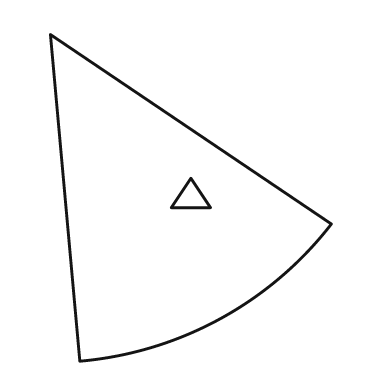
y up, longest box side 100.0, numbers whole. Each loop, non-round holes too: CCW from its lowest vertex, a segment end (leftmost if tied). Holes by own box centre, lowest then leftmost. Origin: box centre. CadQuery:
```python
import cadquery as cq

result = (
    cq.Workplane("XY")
    .moveTo(-34.0, -50.0)
    .threePointArc((9.0, -37.0), (43.0, -8.0))
    .lineTo(-43.0, 50.0)
    .close()
    .moveTo(-6.0, -3.0)
    .lineTo(6.0, -3.0)
    .lineTo(0.0, 6.0)
    .close()
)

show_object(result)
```